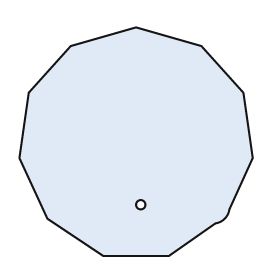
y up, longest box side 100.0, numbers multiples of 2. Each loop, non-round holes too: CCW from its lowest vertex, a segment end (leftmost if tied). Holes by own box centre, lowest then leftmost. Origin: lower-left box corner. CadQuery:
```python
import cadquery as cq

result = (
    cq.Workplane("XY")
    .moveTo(36.0, 0.0)
    .lineTo(64.0, 0.0)
    .lineTo(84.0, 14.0)
    .threePointArc((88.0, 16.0), (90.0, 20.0))
    .lineTo(100.0, 42.0)
    .lineTo(96.0, 70.0)
    .lineTo(78.0, 90.0)
    .lineTo(50.0, 98.0)
    .lineTo(22.0, 90.0)
    .lineTo(4.0, 70.0)
    .lineTo(0.0, 42.0)
    .lineTo(12.0, 16.0)
    .close()
    .moveTo(52.0, 22.0)
    .circle(2.0)
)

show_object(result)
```